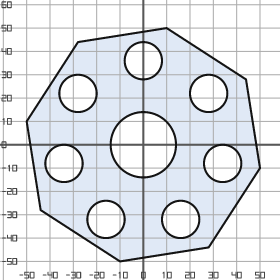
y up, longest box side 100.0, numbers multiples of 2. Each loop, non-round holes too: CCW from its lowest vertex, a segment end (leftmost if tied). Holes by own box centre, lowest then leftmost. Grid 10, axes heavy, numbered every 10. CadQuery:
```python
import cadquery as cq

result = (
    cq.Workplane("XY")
    .moveTo(-10.0, -50.0)
    .lineTo(28.0, -44.0)
    .lineTo(50.0, -10.0)
    .lineTo(44.0, 28.0)
    .lineTo(10.0, 50.0)
    .lineTo(-28.0, 44.0)
    .lineTo(-50.0, 10.0)
    .lineTo(-44.0, -28.0)
    .close()
    .moveTo(-16.0, -32.0)
    .circle(8.0)
    .moveTo(16.0, -32.0)
    .circle(8.0)
    .moveTo(-34.0, -8.0)
    .circle(8.0)
    .moveTo(34.0, -8.0)
    .circle(8.0)
    .moveTo(0.0, 0.0)
    .circle(14.0)
    .moveTo(-28.0, 22.0)
    .circle(8.0)
    .moveTo(28.0, 22.0)
    .circle(8.0)
    .moveTo(0.0, 36.0)
    .circle(8.0)
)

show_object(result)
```